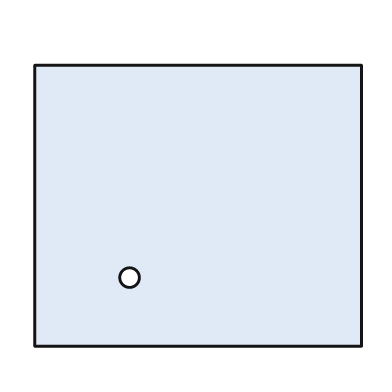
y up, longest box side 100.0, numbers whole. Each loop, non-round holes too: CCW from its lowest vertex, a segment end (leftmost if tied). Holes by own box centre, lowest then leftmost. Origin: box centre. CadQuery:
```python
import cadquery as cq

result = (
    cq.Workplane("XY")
    .moveTo(-50.0, -43.0)
    .lineTo(50.0, -43.0)
    .lineTo(50.0, 43.0)
    .lineTo(-50.0, 43.0)
    .close()
    .moveTo(-21.0, -22.0)
    .circle(3.0)
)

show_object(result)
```